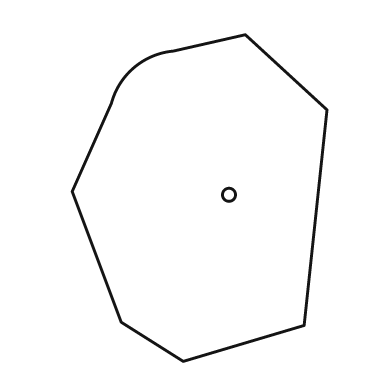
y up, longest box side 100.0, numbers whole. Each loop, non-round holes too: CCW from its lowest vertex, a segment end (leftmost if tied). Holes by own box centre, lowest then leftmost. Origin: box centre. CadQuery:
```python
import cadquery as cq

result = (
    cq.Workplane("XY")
    .moveTo(-5.0, -50.0)
    .lineTo(32.0, -39.0)
    .lineTo(39.0, 27.0)
    .lineTo(14.0, 50.0)
    .lineTo(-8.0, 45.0)
    .threePointArc((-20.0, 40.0), (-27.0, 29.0))
    .lineTo(-39.0, 2.0)
    .lineTo(-24.0, -38.0)
    .close()
    .moveTo(9.0, 1.0)
    .circle(2.0)
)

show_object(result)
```